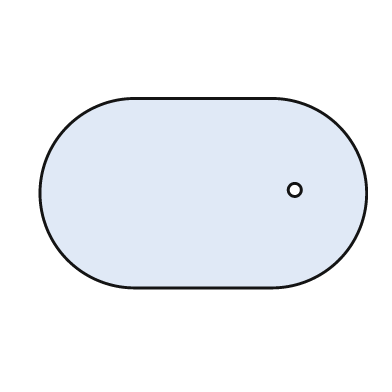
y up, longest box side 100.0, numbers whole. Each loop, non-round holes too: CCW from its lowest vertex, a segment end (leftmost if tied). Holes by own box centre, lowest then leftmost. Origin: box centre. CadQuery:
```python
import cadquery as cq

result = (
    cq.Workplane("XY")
    .moveTo(-21.0, -29.0)
    .lineTo(21.0, -29.0)
    .threePointArc((50.0, 0.0), (21.0, 29.0))
    .lineTo(-21.0, 29.0)
    .threePointArc((-50.0, 0.0), (-21.0, -29.0))
    .close()
    .moveTo(28.0, 1.0)
    .circle(2.0)
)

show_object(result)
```